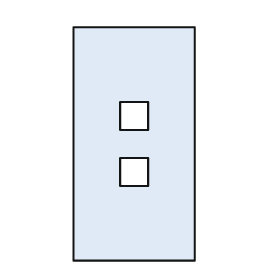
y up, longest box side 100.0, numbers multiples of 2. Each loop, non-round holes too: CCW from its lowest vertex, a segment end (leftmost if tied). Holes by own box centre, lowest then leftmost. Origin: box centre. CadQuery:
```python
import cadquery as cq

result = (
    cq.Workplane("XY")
    .moveTo(-26.0, -50.0)
    .lineTo(26.0, -50.0)
    .lineTo(26.0, 50.0)
    .lineTo(-26.0, 50.0)
    .close()
    .moveTo(-6.0, -18.0)
    .lineTo(6.0, -18.0)
    .lineTo(6.0, -6.0)
    .lineTo(-6.0, -6.0)
    .close()
    .moveTo(-6.0, 6.0)
    .lineTo(6.0, 6.0)
    .lineTo(6.0, 18.0)
    .lineTo(-6.0, 18.0)
    .close()
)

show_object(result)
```